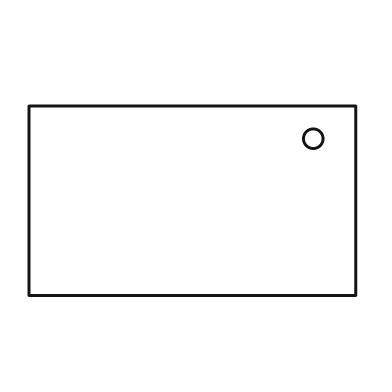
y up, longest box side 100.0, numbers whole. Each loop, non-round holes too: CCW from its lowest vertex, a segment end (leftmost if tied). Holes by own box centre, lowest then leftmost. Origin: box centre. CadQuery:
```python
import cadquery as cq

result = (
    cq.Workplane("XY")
    .moveTo(-50.0, -29.0)
    .lineTo(50.0, -29.0)
    .lineTo(50.0, 29.0)
    .lineTo(-50.0, 29.0)
    .close()
    .moveTo(37.0, 19.0)
    .circle(3.0)
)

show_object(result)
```